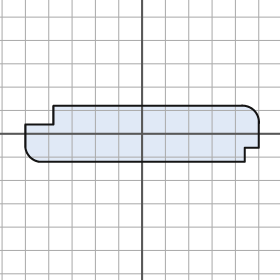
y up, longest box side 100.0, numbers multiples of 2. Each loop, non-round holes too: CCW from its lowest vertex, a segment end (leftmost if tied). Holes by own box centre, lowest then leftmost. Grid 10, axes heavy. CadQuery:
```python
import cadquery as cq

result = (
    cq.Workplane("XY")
    .moveTo(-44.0, -12.0)
    .lineTo(44.0, -12.0)
    .lineTo(44.0, -6.0)
    .lineTo(50.0, -6.0)
    .lineTo(50.0, 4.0)
    .threePointArc((48.0, 10.0), (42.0, 12.0))
    .lineTo(-38.0, 12.0)
    .lineTo(-38.0, 4.0)
    .lineTo(-50.0, 4.0)
    .lineTo(-50.0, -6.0)
    .threePointArc((-48.0, -10.0), (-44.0, -12.0))
    .close()
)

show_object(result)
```